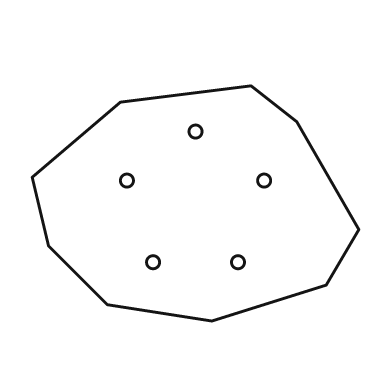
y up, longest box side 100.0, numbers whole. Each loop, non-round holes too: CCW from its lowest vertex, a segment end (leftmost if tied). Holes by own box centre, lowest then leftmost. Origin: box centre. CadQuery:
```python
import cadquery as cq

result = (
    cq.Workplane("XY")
    .moveTo(5.0, -36.0)
    .lineTo(40.0, -25.0)
    .lineTo(50.0, -8.0)
    .lineTo(31.0, 25.0)
    .lineTo(17.0, 36.0)
    .lineTo(-23.0, 31.0)
    .lineTo(-50.0, 8.0)
    .lineTo(-45.0, -13.0)
    .lineTo(-27.0, -31.0)
    .close()
    .moveTo(-13.0, -18.0)
    .circle(2.0)
    .moveTo(13.0, -18.0)
    .circle(2.0)
    .moveTo(-21.0, 7.0)
    .circle(2.0)
    .moveTo(21.0, 7.0)
    .circle(2.0)
    .moveTo(0.0, 22.0)
    .circle(2.0)
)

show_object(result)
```